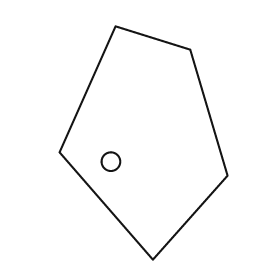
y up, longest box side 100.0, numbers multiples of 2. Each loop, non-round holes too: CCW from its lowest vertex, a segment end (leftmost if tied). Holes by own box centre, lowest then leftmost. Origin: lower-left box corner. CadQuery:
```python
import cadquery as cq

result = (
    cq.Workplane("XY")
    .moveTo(40.0, 0.0)
    .lineTo(72.0, 36.0)
    .lineTo(56.0, 90.0)
    .lineTo(24.0, 100.0)
    .lineTo(0.0, 46.0)
    .close()
    .moveTo(22.0, 42.0)
    .circle(4.0)
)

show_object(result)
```